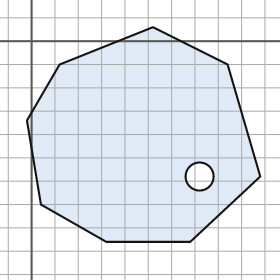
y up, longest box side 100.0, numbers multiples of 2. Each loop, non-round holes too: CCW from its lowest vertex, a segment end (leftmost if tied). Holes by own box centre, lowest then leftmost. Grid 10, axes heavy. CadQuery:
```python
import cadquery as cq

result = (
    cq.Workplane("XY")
    .moveTo(32.0, -86.0)
    .lineTo(68.0, -86.0)
    .lineTo(98.0, -58.0)
    .lineTo(84.0, -10.0)
    .lineTo(52.0, 6.0)
    .lineTo(12.0, -10.0)
    .lineTo(-2.0, -34.0)
    .lineTo(4.0, -70.0)
    .close()
    .moveTo(72.0, -58.0)
    .circle(6.0)
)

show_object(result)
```